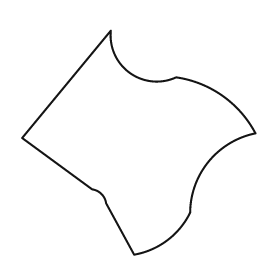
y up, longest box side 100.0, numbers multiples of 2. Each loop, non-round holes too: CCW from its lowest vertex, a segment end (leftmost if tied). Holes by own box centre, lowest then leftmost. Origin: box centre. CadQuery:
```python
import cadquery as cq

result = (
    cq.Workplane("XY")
    .moveTo(-2.0, -48.0)
    .threePointArc((12.0, -42.0), (22.0, -30.0))
    .threePointArc((30.0, -8.0), (50.0, 4.0))
    .threePointArc((36.0, 20.0), (16.0, 28.0))
    .threePointArc((-4.0, 30.0), (-12.0, 48.0))
    .lineTo(-50.0, 2.0)
    .lineTo(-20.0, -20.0)
    .threePointArc((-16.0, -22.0), (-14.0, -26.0))
    .close()
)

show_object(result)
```